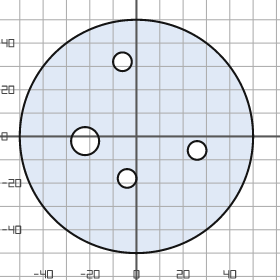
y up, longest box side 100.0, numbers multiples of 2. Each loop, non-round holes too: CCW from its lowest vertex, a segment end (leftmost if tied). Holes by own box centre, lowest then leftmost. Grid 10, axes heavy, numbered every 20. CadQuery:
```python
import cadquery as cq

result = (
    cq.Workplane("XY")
    .moveTo(0.0, 0.0)
    .circle(50.0)
    .moveTo(-4.0, -18.0)
    .circle(4.0)
    .moveTo(26.0, -6.0)
    .circle(4.0)
    .moveTo(-22.0, -2.0)
    .circle(6.0)
    .moveTo(-6.0, 32.0)
    .circle(4.0)
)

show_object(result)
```